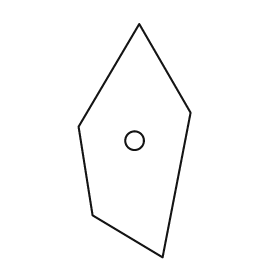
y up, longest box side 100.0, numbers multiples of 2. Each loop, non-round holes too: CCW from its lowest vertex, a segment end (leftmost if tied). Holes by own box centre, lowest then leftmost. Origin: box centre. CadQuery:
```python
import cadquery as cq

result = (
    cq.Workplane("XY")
    .moveTo(12.0, -50.0)
    .lineTo(24.0, 12.0)
    .lineTo(2.0, 50.0)
    .lineTo(-24.0, 6.0)
    .lineTo(-18.0, -32.0)
    .close()
    .moveTo(0.0, 0.0)
    .circle(4.0)
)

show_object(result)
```